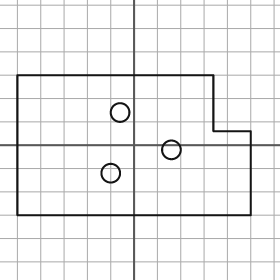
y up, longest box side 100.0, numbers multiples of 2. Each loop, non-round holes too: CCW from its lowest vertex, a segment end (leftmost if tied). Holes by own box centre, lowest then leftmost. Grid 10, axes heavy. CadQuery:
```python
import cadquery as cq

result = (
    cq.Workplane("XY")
    .moveTo(-50.0, -30.0)
    .lineTo(50.0, -30.0)
    .lineTo(50.0, 6.0)
    .lineTo(34.0, 6.0)
    .lineTo(34.0, 30.0)
    .lineTo(-50.0, 30.0)
    .close()
    .moveTo(-10.0, -12.0)
    .circle(4.0)
    .moveTo(16.0, -2.0)
    .circle(4.0)
    .moveTo(-6.0, 14.0)
    .circle(4.0)
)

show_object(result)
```